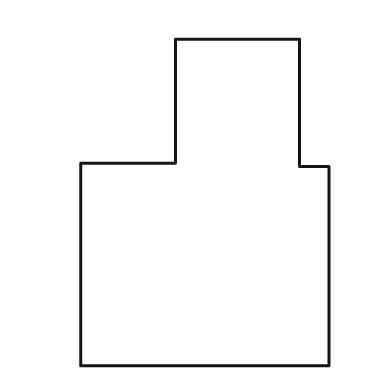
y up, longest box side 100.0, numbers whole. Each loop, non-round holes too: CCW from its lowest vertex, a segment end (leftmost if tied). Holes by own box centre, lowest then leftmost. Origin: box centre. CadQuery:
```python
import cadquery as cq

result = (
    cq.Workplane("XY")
    .moveTo(-38.0, -50.0)
    .lineTo(38.0, -50.0)
    .lineTo(38.0, 11.0)
    .lineTo(29.0, 11.0)
    .lineTo(29.0, 50.0)
    .lineTo(-9.0, 50.0)
    .lineTo(-9.0, 12.0)
    .lineTo(-38.0, 12.0)
    .close()
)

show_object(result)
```